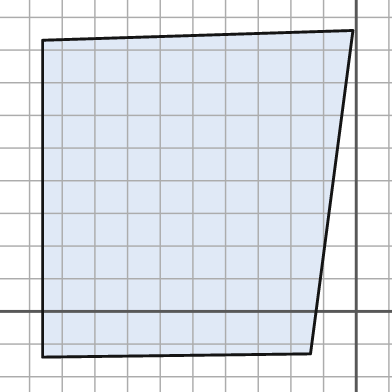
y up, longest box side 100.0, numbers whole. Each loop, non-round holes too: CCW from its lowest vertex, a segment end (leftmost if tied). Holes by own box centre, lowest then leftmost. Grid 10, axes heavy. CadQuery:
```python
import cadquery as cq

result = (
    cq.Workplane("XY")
    .moveTo(-96.0, -14.0)
    .lineTo(-14.0, -13.0)
    .lineTo(-1.0, 86.0)
    .lineTo(-96.0, 83.0)
    .close()
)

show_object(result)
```